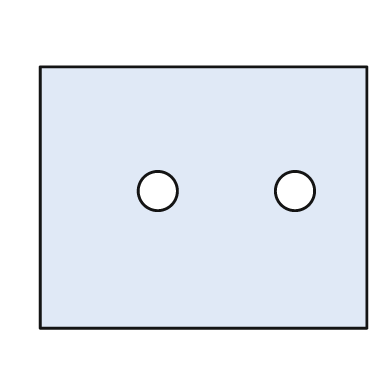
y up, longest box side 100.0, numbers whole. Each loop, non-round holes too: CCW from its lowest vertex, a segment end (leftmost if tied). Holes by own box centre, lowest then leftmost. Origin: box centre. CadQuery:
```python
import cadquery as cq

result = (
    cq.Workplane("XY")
    .moveTo(-50.0, -40.0)
    .lineTo(50.0, -40.0)
    .lineTo(50.0, 40.0)
    .lineTo(-50.0, 40.0)
    .close()
    .moveTo(-14.0, 2.0)
    .circle(6.0)
    .moveTo(28.0, 2.0)
    .circle(6.0)
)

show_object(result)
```